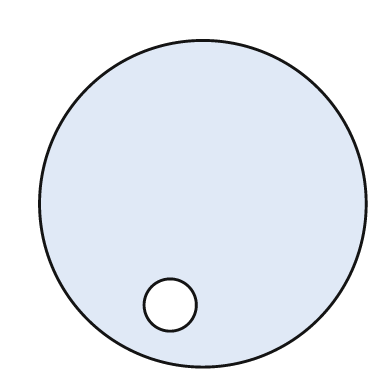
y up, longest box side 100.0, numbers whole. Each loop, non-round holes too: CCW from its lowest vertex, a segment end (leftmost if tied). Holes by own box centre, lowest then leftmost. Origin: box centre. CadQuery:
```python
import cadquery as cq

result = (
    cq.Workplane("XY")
    .moveTo(0.0, 0.0)
    .circle(50.0)
    .moveTo(-10.0, -31.0)
    .circle(8.0)
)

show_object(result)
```